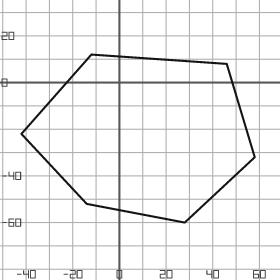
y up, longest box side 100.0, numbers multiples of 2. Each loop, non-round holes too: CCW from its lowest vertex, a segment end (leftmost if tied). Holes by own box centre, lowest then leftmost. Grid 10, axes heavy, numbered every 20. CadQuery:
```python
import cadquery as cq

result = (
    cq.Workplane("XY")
    .moveTo(28.0, -60.0)
    .lineTo(58.0, -32.0)
    .lineTo(46.0, 8.0)
    .lineTo(-12.0, 12.0)
    .lineTo(-42.0, -22.0)
    .lineTo(-14.0, -52.0)
    .close()
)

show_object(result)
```